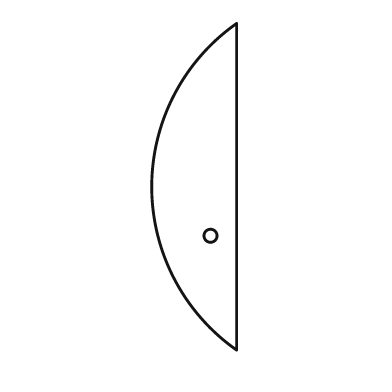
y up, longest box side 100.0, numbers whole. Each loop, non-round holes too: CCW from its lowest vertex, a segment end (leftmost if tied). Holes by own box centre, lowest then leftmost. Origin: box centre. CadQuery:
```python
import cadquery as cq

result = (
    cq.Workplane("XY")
    .moveTo(13.0, -50.0)
    .lineTo(13.0, 50.0)
    .threePointArc((-13.0, 0.0), (13.0, -50.0))
    .close()
    .moveTo(5.0, -15.0)
    .circle(2.0)
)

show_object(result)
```